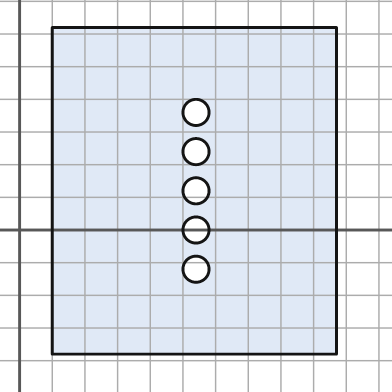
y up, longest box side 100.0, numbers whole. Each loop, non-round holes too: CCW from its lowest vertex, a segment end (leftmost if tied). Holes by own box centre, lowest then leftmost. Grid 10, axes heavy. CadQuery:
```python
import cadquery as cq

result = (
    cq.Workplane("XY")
    .moveTo(10.0, -38.0)
    .lineTo(97.0, -38.0)
    .lineTo(97.0, 62.0)
    .lineTo(10.0, 62.0)
    .close()
    .moveTo(54.0, -12.0)
    .circle(4.0)
    .moveTo(54.0, 0.0)
    .circle(4.0)
    .moveTo(54.0, 12.0)
    .circle(4.0)
    .moveTo(54.0, 24.0)
    .circle(4.0)
    .moveTo(54.0, 36.0)
    .circle(4.0)
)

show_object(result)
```